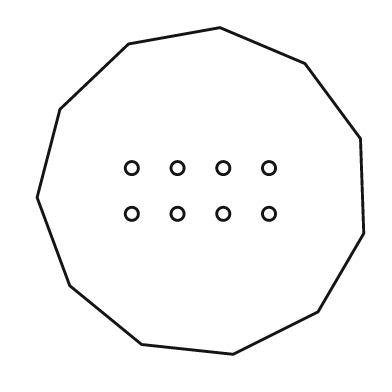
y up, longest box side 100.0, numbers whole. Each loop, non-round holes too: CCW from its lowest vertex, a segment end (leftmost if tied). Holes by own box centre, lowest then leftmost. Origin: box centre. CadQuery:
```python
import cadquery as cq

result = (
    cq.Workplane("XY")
    .moveTo(10.0, -50.0)
    .lineTo(36.0, -37.0)
    .lineTo(50.0, -13.0)
    .lineTo(49.0, 16.0)
    .lineTo(32.0, 39.0)
    .lineTo(6.0, 50.0)
    .lineTo(-22.0, 45.0)
    .lineTo(-43.0, 25.0)
    .lineTo(-50.0, -2.0)
    .lineTo(-40.0, -29.0)
    .lineTo(-18.0, -47.0)
    .close()
    .moveTo(-21.0, -7.0)
    .circle(2.0)
    .moveTo(-7.0, -7.0)
    .circle(2.0)
    .moveTo(7.0, -7.0)
    .circle(2.0)
    .moveTo(21.0, -7.0)
    .circle(2.0)
    .moveTo(-21.0, 7.0)
    .circle(2.0)
    .moveTo(-7.0, 7.0)
    .circle(2.0)
    .moveTo(7.0, 7.0)
    .circle(2.0)
    .moveTo(21.0, 7.0)
    .circle(2.0)
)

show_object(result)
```